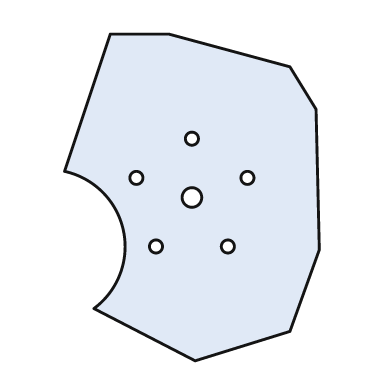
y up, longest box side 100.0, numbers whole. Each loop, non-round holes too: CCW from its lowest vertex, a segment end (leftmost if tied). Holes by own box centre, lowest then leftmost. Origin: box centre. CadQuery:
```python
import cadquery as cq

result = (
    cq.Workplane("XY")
    .moveTo(1.0, -50.0)
    .lineTo(30.0, -41.0)
    .lineTo(39.0, -16.0)
    .lineTo(38.0, 27.0)
    .lineTo(30.0, 40.0)
    .lineTo(-7.0, 50.0)
    .lineTo(-25.0, 50.0)
    .lineTo(-39.0, 8.0)
    .threePointArc((-21.0, -10.0), (-30.0, -34.0))
    .close()
    .moveTo(-11.0, -15.0)
    .circle(2.0)
    .moveTo(11.0, -15.0)
    .circle(2.0)
    .moveTo(0.0, 0.0)
    .circle(3.0)
    .moveTo(-17.0, 6.0)
    .circle(2.0)
    .moveTo(17.0, 6.0)
    .circle(2.0)
    .moveTo(0.0, 18.0)
    .circle(2.0)
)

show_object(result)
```